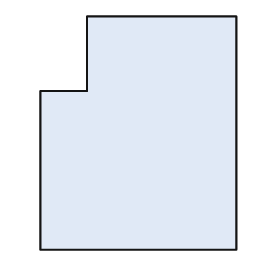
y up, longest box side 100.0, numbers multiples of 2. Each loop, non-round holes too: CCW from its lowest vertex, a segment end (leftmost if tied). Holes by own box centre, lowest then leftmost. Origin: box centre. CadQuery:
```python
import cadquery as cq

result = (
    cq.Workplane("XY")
    .moveTo(-42.0, -50.0)
    .lineTo(42.0, -50.0)
    .lineTo(42.0, 50.0)
    .lineTo(-22.0, 50.0)
    .lineTo(-22.0, 18.0)
    .lineTo(-42.0, 18.0)
    .close()
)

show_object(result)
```